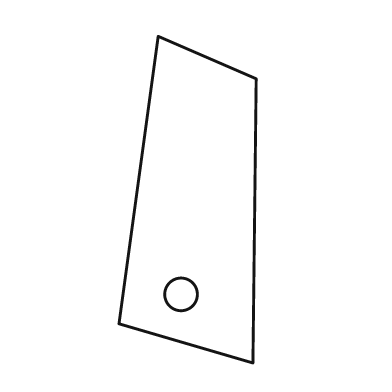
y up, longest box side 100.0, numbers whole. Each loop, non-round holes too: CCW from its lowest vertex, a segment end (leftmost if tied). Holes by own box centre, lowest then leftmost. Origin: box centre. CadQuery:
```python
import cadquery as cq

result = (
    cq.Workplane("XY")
    .moveTo(20.0, -50.0)
    .lineTo(21.0, 37.0)
    .lineTo(-9.0, 50.0)
    .lineTo(-21.0, -38.0)
    .close()
    .moveTo(-2.0, -29.0)
    .circle(5.0)
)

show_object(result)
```